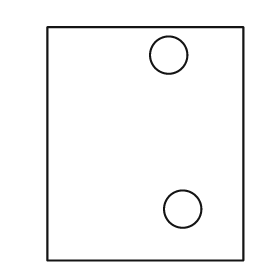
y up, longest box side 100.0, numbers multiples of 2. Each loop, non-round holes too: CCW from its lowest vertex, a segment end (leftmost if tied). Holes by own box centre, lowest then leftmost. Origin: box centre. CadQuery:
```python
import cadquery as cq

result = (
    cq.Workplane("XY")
    .moveTo(-42.0, -50.0)
    .lineTo(42.0, -50.0)
    .lineTo(42.0, 50.0)
    .lineTo(-42.0, 50.0)
    .close()
    .moveTo(16.0, -28.0)
    .circle(8.0)
    .moveTo(10.0, 38.0)
    .circle(8.0)
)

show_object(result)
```